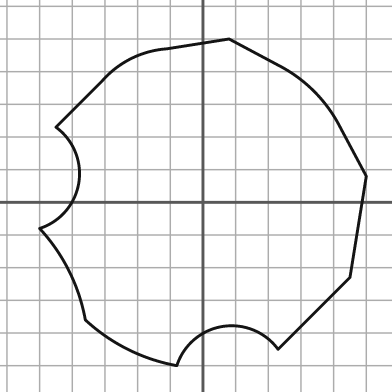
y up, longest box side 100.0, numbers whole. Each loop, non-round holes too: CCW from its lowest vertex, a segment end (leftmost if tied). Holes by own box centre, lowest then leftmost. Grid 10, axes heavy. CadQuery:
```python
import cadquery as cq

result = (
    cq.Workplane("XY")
    .moveTo(-8.0, -50.0)
    .threePointArc((6.0, -38.0), (23.0, -45.0))
    .lineTo(45.0, -23.0)
    .lineTo(50.0, 8.0)
    .lineTo(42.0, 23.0)
    .threePointArc((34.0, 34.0), (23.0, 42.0))
    .lineTo(8.0, 50.0)
    .lineTo(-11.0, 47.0)
    .threePointArc((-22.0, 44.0), (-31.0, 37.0))
    .lineTo(-45.0, 23.0)
    .threePointArc((-38.0, 6.0), (-50.0, -8.0))
    .threePointArc((-41.0, -21.0), (-36.0, -36.0))
    .threePointArc((-23.0, -45.0), (-8.0, -50.0))
    .close()
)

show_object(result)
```